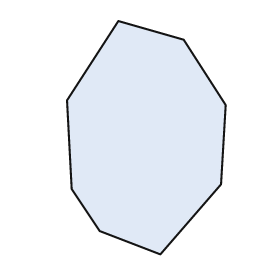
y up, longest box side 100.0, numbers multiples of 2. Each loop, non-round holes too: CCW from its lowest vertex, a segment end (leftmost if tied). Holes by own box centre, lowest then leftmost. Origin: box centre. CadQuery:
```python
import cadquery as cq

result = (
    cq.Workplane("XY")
    .moveTo(6.0, -50.0)
    .lineTo(32.0, -20.0)
    .lineTo(34.0, 14.0)
    .lineTo(16.0, 42.0)
    .lineTo(-12.0, 50.0)
    .lineTo(-34.0, 16.0)
    .lineTo(-32.0, -22.0)
    .lineTo(-20.0, -40.0)
    .close()
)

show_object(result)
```